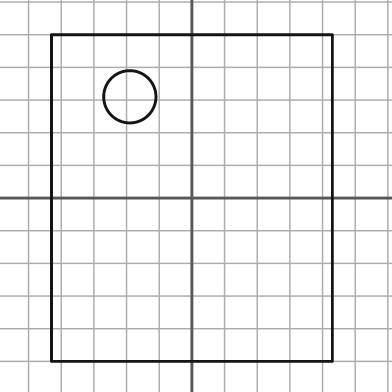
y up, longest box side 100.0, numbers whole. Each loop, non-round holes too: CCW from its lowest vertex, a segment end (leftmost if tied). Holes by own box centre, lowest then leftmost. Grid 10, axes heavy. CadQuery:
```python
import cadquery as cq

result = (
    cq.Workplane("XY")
    .moveTo(-43.0, -50.0)
    .lineTo(43.0, -50.0)
    .lineTo(43.0, 50.0)
    .lineTo(-43.0, 50.0)
    .close()
    .moveTo(-19.0, 31.0)
    .circle(8.0)
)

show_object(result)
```